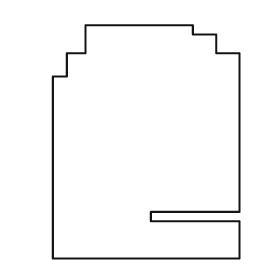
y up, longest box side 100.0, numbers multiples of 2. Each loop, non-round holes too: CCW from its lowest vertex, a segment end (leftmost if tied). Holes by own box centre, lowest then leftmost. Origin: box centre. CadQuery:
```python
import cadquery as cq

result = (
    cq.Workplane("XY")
    .moveTo(-40.0, -50.0)
    .lineTo(40.0, -50.0)
    .lineTo(40.0, -34.0)
    .lineTo(2.0, -34.0)
    .lineTo(2.0, -30.0)
    .lineTo(40.0, -30.0)
    .lineTo(40.0, 38.0)
    .lineTo(30.0, 38.0)
    .lineTo(30.0, 46.0)
    .lineTo(20.0, 46.0)
    .lineTo(20.0, 50.0)
    .lineTo(-26.0, 50.0)
    .lineTo(-26.0, 38.0)
    .lineTo(-34.0, 38.0)
    .lineTo(-34.0, 28.0)
    .lineTo(-40.0, 28.0)
    .close()
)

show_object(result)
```